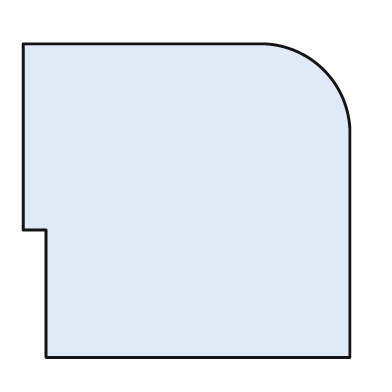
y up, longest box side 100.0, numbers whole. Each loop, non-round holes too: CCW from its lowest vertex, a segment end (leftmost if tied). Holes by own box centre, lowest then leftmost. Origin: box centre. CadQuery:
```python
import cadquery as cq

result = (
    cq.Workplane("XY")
    .moveTo(-43.0, -48.0)
    .lineTo(50.0, -48.0)
    .lineTo(50.0, 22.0)
    .threePointArc((42.0, 40.0), (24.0, 48.0))
    .lineTo(-50.0, 48.0)
    .lineTo(-50.0, -9.0)
    .lineTo(-43.0, -9.0)
    .close()
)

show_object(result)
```